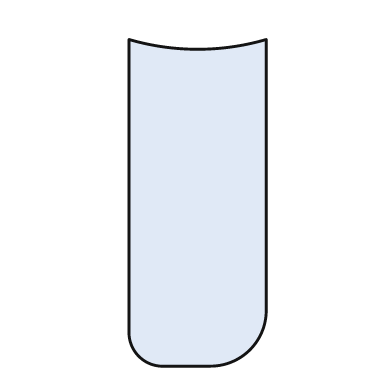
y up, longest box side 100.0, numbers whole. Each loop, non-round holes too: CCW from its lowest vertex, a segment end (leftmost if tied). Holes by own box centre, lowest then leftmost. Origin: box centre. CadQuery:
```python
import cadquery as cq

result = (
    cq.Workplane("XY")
    .moveTo(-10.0, -50.0)
    .lineTo(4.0, -50.0)
    .threePointArc((16.0, -45.0), (21.0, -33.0))
    .lineTo(21.0, 50.0)
    .threePointArc((0.0, 47.0), (-21.0, 50.0))
    .lineTo(-21.0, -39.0)
    .threePointArc((-18.0, -47.0), (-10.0, -50.0))
    .close()
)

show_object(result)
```